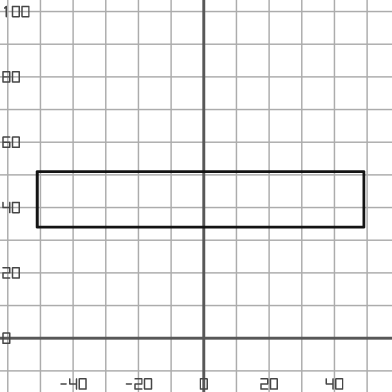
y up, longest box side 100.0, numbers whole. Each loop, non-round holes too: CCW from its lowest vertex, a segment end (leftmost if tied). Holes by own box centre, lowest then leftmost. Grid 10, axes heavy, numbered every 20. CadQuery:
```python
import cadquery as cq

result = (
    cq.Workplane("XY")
    .moveTo(-51.0, 34.0)
    .lineTo(49.0, 34.0)
    .lineTo(49.0, 51.0)
    .lineTo(-51.0, 51.0)
    .close()
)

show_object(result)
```